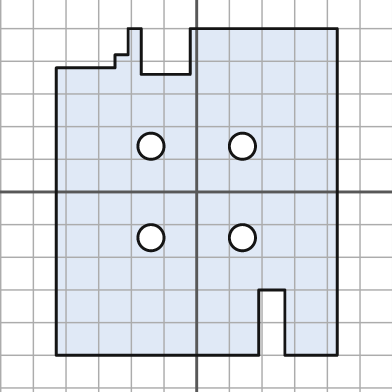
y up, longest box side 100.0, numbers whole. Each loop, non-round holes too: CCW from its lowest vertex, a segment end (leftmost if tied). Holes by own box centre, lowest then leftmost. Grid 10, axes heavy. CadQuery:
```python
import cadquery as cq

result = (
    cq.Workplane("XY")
    .moveTo(-43.0, -50.0)
    .lineTo(19.0, -50.0)
    .lineTo(19.0, -30.0)
    .lineTo(27.0, -30.0)
    .lineTo(27.0, -50.0)
    .lineTo(43.0, -50.0)
    .lineTo(43.0, 50.0)
    .lineTo(-2.0, 50.0)
    .lineTo(-2.0, 36.0)
    .lineTo(-17.0, 36.0)
    .lineTo(-17.0, 50.0)
    .lineTo(-21.0, 50.0)
    .lineTo(-21.0, 42.0)
    .lineTo(-25.0, 42.0)
    .lineTo(-25.0, 38.0)
    .lineTo(-43.0, 38.0)
    .close()
    .moveTo(-14.0, -14.0)
    .circle(4.0)
    .moveTo(14.0, -14.0)
    .circle(4.0)
    .moveTo(-14.0, 14.0)
    .circle(4.0)
    .moveTo(14.0, 14.0)
    .circle(4.0)
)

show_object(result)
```